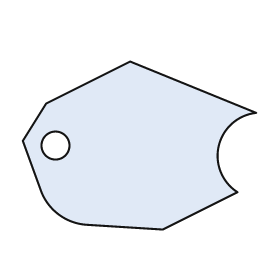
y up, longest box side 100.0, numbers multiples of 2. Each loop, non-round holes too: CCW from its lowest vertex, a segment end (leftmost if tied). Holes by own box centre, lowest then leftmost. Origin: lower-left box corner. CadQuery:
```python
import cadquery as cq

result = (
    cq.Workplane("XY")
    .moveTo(60.0, 0.0)
    .lineTo(92.0, 16.0)
    .threePointArc((84.0, 36.0), (100.0, 50.0))
    .lineTo(46.0, 72.0)
    .lineTo(10.0, 54.0)
    .lineTo(0.0, 38.0)
    .lineTo(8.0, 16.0)
    .threePointArc((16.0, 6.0), (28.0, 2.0))
    .close()
    .moveTo(14.0, 36.0)
    .circle(6.0)
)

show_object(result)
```